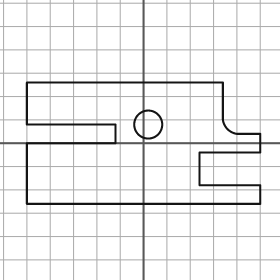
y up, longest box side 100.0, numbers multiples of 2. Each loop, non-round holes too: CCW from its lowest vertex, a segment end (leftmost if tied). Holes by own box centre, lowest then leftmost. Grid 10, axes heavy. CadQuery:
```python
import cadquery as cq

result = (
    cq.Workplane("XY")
    .moveTo(-50.0, -26.0)
    .lineTo(50.0, -26.0)
    .lineTo(50.0, -18.0)
    .lineTo(24.0, -18.0)
    .lineTo(24.0, -4.0)
    .lineTo(50.0, -4.0)
    .lineTo(50.0, 4.0)
    .lineTo(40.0, 4.0)
    .threePointArc((36.0, 6.0), (34.0, 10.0))
    .lineTo(34.0, 26.0)
    .lineTo(-50.0, 26.0)
    .lineTo(-50.0, 8.0)
    .lineTo(-12.0, 8.0)
    .lineTo(-12.0, 0.0)
    .lineTo(-50.0, 0.0)
    .close()
    .moveTo(2.0, 8.0)
    .circle(6.0)
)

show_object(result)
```